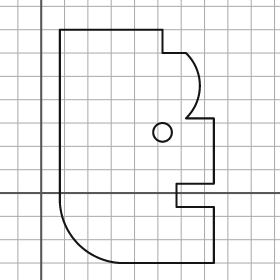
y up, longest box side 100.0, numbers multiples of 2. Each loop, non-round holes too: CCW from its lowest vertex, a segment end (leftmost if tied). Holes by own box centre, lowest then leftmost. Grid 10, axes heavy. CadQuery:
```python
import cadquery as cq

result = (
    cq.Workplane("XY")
    .moveTo(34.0, -30.0)
    .lineTo(74.0, -30.0)
    .lineTo(74.0, -6.0)
    .lineTo(58.0, -6.0)
    .lineTo(58.0, 4.0)
    .lineTo(74.0, 4.0)
    .lineTo(74.0, 32.0)
    .lineTo(62.0, 32.0)
    .threePointArc((68.0, 46.0), (62.0, 60.0))
    .lineTo(52.0, 60.0)
    .lineTo(52.0, 70.0)
    .lineTo(8.0, 70.0)
    .lineTo(8.0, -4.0)
    .threePointArc((16.0, -22.0), (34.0, -30.0))
    .close()
    .moveTo(52.0, 26.0)
    .circle(4.0)
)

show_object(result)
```